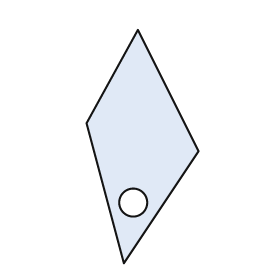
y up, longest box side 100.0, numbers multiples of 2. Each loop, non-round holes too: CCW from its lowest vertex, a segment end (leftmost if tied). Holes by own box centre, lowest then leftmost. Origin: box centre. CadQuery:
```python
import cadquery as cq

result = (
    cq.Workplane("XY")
    .moveTo(-8.0, -50.0)
    .lineTo(24.0, -2.0)
    .lineTo(-2.0, 50.0)
    .lineTo(-24.0, 10.0)
    .close()
    .moveTo(-4.0, -24.0)
    .circle(6.0)
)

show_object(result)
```